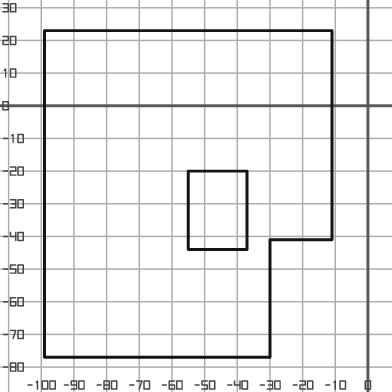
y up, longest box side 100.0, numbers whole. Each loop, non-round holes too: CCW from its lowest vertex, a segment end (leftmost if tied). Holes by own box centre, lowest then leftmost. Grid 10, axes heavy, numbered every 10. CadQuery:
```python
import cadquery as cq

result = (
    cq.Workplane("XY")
    .moveTo(-99.0, -77.0)
    .lineTo(-30.0, -77.0)
    .lineTo(-30.0, -41.0)
    .lineTo(-11.0, -41.0)
    .lineTo(-11.0, 23.0)
    .lineTo(-99.0, 23.0)
    .close()
    .moveTo(-55.0, -44.0)
    .lineTo(-37.0, -44.0)
    .lineTo(-37.0, -20.0)
    .lineTo(-55.0, -20.0)
    .close()
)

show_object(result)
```